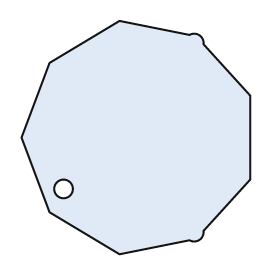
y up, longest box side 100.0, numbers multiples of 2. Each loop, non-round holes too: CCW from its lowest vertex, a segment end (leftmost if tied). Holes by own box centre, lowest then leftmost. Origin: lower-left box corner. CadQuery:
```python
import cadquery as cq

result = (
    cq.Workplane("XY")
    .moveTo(42.0, 0.0)
    .lineTo(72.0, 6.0)
    .threePointArc((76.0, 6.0), (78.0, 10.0))
    .lineTo(98.0, 32.0)
    .lineTo(98.0, 68.0)
    .lineTo(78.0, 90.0)
    .threePointArc((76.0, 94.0), (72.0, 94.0))
    .lineTo(42.0, 100.0)
    .lineTo(12.0, 82.0)
    .lineTo(0.0, 50.0)
    .lineTo(12.0, 18.0)
    .close()
    .moveTo(18.0, 28.0)
    .circle(4.0)
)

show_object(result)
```